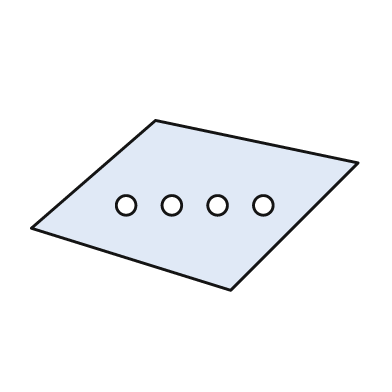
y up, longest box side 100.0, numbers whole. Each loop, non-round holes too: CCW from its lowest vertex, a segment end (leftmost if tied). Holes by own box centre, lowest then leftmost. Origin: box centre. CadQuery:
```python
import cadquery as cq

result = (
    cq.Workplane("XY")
    .moveTo(11.0, -26.0)
    .lineTo(50.0, 13.0)
    .lineTo(-12.0, 26.0)
    .lineTo(-50.0, -7.0)
    .close()
    .moveTo(-21.0, 0.0)
    .circle(3.0)
    .moveTo(-7.0, 0.0)
    .circle(3.0)
    .moveTo(7.0, 0.0)
    .circle(3.0)
    .moveTo(21.0, 0.0)
    .circle(3.0)
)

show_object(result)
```